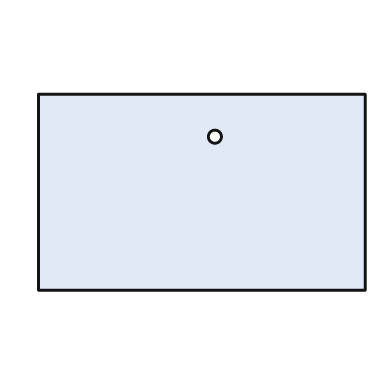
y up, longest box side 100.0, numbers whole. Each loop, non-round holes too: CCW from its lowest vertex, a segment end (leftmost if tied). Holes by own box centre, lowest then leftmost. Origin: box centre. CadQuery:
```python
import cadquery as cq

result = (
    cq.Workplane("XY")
    .moveTo(-50.0, -30.0)
    .lineTo(50.0, -30.0)
    .lineTo(50.0, 30.0)
    .lineTo(-50.0, 30.0)
    .close()
    .moveTo(4.0, 17.0)
    .circle(2.0)
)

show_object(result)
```